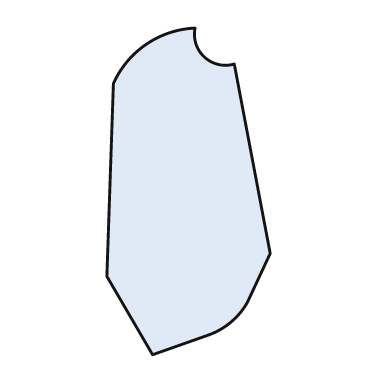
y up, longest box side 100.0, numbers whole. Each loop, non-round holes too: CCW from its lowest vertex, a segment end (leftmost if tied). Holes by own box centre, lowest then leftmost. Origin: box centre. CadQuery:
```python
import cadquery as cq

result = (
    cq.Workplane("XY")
    .moveTo(-11.0, -50.0)
    .lineTo(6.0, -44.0)
    .threePointArc((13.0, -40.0), (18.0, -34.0))
    .lineTo(25.0, -19.0)
    .lineTo(14.0, 39.0)
    .threePointArc((5.0, 41.0), (2.0, 50.0))
    .threePointArc((-13.0, 45.0), (-23.0, 33.0))
    .lineTo(-25.0, -26.0)
    .close()
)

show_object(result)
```